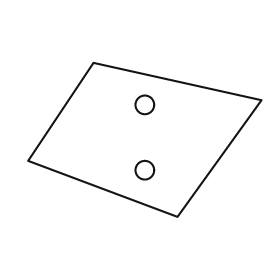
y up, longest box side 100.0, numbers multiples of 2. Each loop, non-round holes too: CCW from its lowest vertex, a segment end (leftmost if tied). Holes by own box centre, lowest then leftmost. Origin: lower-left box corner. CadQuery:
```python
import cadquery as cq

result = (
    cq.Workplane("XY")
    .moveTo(64.0, 0.0)
    .lineTo(100.0, 50.0)
    .lineTo(28.0, 66.0)
    .lineTo(0.0, 24.0)
    .close()
    .moveTo(50.0, 20.0)
    .circle(4.0)
    .moveTo(50.0, 48.0)
    .circle(4.0)
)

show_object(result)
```